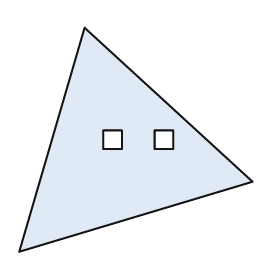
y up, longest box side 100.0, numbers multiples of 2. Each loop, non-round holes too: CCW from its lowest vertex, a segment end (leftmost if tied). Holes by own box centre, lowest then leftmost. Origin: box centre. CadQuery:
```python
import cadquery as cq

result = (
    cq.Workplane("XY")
    .moveTo(-50.0, -48.0)
    .lineTo(50.0, -18.0)
    .lineTo(-22.0, 48.0)
    .close()
    .moveTo(-14.0, -4.0)
    .lineTo(-6.0, -4.0)
    .lineTo(-6.0, 4.0)
    .lineTo(-14.0, 4.0)
    .close()
    .moveTo(8.0, -4.0)
    .lineTo(16.0, -4.0)
    .lineTo(16.0, 4.0)
    .lineTo(8.0, 4.0)
    .close()
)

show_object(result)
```